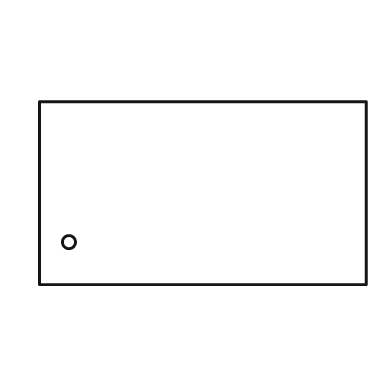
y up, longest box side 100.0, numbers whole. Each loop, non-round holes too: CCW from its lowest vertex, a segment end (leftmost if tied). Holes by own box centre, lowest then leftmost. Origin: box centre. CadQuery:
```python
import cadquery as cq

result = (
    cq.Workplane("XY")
    .moveTo(-50.0, -28.0)
    .lineTo(50.0, -28.0)
    .lineTo(50.0, 28.0)
    .lineTo(-50.0, 28.0)
    .close()
    .moveTo(-41.0, -15.0)
    .circle(2.0)
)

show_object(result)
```